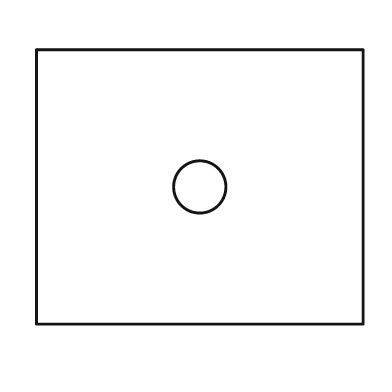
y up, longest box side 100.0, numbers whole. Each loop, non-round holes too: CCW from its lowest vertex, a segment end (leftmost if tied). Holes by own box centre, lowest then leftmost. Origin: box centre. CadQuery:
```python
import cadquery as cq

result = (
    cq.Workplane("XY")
    .moveTo(-50.0, -42.0)
    .lineTo(50.0, -42.0)
    .lineTo(50.0, 42.0)
    .lineTo(-50.0, 42.0)
    .close()
    .moveTo(0.0, 0.0)
    .circle(8.0)
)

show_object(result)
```